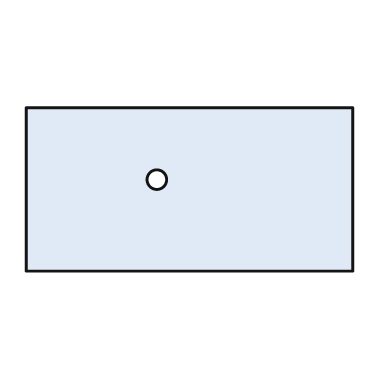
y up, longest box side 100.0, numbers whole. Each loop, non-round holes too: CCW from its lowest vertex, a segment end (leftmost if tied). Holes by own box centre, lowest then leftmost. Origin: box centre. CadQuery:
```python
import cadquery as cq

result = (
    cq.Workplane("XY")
    .moveTo(-50.0, -25.0)
    .lineTo(50.0, -25.0)
    .lineTo(50.0, 25.0)
    .lineTo(-50.0, 25.0)
    .close()
    .moveTo(-10.0, 3.0)
    .circle(3.0)
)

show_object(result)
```